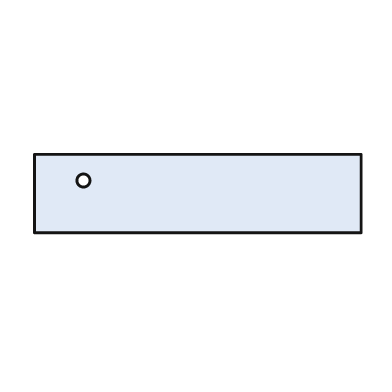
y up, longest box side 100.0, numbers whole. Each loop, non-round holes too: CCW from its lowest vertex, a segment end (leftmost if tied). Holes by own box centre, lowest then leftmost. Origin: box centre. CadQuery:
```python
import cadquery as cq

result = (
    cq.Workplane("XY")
    .moveTo(-50.0, -12.0)
    .lineTo(50.0, -12.0)
    .lineTo(50.0, 12.0)
    .lineTo(-50.0, 12.0)
    .close()
    .moveTo(-35.0, 4.0)
    .circle(2.0)
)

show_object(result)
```